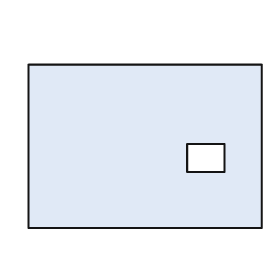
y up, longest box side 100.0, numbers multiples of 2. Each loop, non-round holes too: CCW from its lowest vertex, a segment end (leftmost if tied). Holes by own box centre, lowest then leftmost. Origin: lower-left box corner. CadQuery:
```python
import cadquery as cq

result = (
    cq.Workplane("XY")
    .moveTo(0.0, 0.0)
    .lineTo(100.0, 0.0)
    .lineTo(100.0, 70.0)
    .lineTo(0.0, 70.0)
    .close()
    .moveTo(68.0, 24.0)
    .lineTo(84.0, 24.0)
    .lineTo(84.0, 36.0)
    .lineTo(68.0, 36.0)
    .close()
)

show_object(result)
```